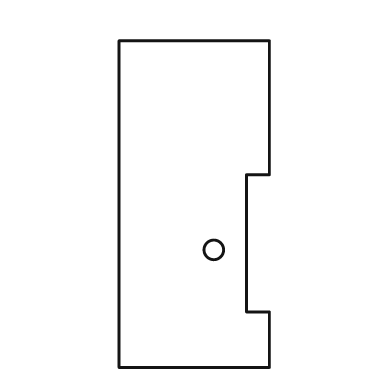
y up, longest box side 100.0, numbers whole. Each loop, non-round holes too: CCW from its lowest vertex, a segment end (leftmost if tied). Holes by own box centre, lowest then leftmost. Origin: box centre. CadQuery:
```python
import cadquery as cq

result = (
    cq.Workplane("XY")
    .moveTo(-23.0, -50.0)
    .lineTo(23.0, -50.0)
    .lineTo(23.0, -33.0)
    .lineTo(16.0, -33.0)
    .lineTo(16.0, 9.0)
    .lineTo(23.0, 9.0)
    .lineTo(23.0, 50.0)
    .lineTo(-23.0, 50.0)
    .close()
    .moveTo(6.0, -14.0)
    .circle(3.0)
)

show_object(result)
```